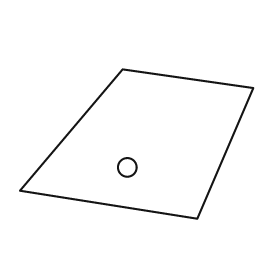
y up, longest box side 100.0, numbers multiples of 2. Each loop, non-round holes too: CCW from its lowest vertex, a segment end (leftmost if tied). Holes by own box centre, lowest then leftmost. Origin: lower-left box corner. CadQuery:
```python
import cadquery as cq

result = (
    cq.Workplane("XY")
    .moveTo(76.0, 0.0)
    .lineTo(100.0, 56.0)
    .lineTo(44.0, 64.0)
    .lineTo(0.0, 12.0)
    .close()
    .moveTo(46.0, 22.0)
    .circle(4.0)
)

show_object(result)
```